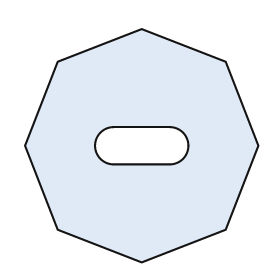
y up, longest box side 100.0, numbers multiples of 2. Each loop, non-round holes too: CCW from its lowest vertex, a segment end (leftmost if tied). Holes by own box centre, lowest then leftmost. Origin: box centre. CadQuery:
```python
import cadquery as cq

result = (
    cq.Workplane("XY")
    .moveTo(0.0, -50.0)
    .lineTo(36.0, -36.0)
    .lineTo(50.0, 0.0)
    .lineTo(36.0, 36.0)
    .lineTo(0.0, 50.0)
    .lineTo(-36.0, 36.0)
    .lineTo(-50.0, 0.0)
    .lineTo(-36.0, -36.0)
    .close()
    .moveTo(-12.0, -8.0)
    .lineTo(12.0, -8.0)
    .threePointArc((20.0, 0.0), (12.0, 8.0))
    .lineTo(-12.0, 8.0)
    .threePointArc((-20.0, 0.0), (-12.0, -8.0))
    .close()
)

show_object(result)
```